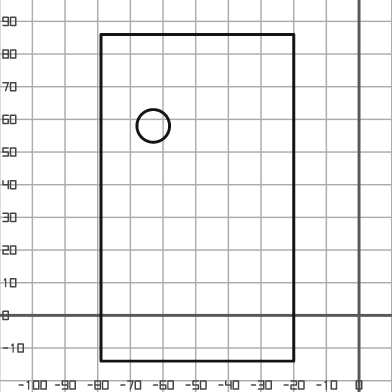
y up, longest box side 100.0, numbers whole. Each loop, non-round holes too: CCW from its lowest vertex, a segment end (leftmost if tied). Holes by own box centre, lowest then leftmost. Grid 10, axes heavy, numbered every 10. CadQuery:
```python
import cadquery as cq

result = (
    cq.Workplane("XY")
    .moveTo(-79.0, -14.0)
    .lineTo(-20.0, -14.0)
    .lineTo(-20.0, 86.0)
    .lineTo(-79.0, 86.0)
    .close()
    .moveTo(-63.0, 58.0)
    .circle(5.0)
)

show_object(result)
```